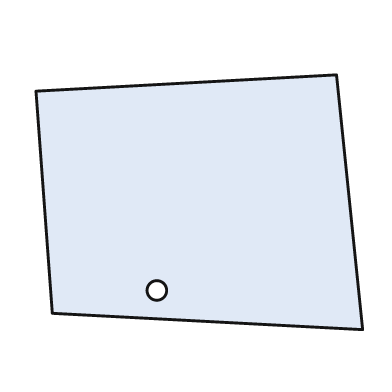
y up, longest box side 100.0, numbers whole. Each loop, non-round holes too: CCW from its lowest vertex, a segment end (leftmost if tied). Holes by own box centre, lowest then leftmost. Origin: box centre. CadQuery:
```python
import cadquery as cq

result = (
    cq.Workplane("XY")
    .moveTo(50.0, -39.0)
    .lineTo(42.0, 39.0)
    .lineTo(-50.0, 34.0)
    .lineTo(-45.0, -34.0)
    .close()
    .moveTo(-13.0, -27.0)
    .circle(3.0)
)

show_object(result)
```